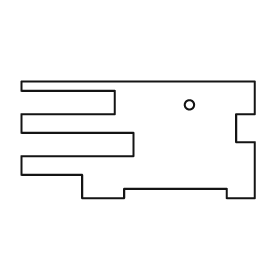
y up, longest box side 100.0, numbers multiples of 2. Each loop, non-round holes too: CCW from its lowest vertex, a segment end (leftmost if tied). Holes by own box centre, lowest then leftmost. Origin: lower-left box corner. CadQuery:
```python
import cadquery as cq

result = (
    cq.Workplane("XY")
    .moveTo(26.0, 0.0)
    .lineTo(44.0, 0.0)
    .lineTo(44.0, 4.0)
    .lineTo(88.0, 4.0)
    .lineTo(88.0, 0.0)
    .lineTo(100.0, 0.0)
    .lineTo(100.0, 24.0)
    .lineTo(92.0, 24.0)
    .lineTo(92.0, 36.0)
    .lineTo(100.0, 36.0)
    .lineTo(100.0, 50.0)
    .lineTo(0.0, 50.0)
    .lineTo(0.0, 46.0)
    .lineTo(40.0, 46.0)
    .lineTo(40.0, 36.0)
    .lineTo(0.0, 36.0)
    .lineTo(0.0, 28.0)
    .lineTo(48.0, 28.0)
    .lineTo(48.0, 18.0)
    .lineTo(0.0, 18.0)
    .lineTo(0.0, 10.0)
    .lineTo(26.0, 10.0)
    .close()
    .moveTo(72.0, 40.0)
    .circle(2.0)
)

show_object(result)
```